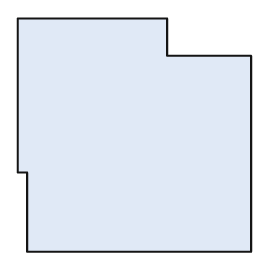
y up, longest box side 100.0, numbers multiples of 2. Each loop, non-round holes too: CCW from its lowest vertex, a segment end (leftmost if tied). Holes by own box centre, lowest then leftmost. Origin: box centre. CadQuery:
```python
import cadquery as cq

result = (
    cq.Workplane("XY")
    .moveTo(-46.0, -50.0)
    .lineTo(50.0, -50.0)
    .lineTo(50.0, 34.0)
    .lineTo(14.0, 34.0)
    .lineTo(14.0, 50.0)
    .lineTo(-50.0, 50.0)
    .lineTo(-50.0, -16.0)
    .lineTo(-46.0, -16.0)
    .close()
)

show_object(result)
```